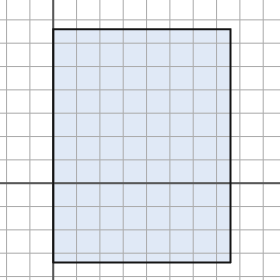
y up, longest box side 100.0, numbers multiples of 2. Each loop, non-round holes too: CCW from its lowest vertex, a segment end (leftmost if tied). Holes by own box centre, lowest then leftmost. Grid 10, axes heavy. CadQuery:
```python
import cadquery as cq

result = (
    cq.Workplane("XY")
    .moveTo(0.0, -34.0)
    .lineTo(76.0, -34.0)
    .lineTo(76.0, 66.0)
    .lineTo(0.0, 66.0)
    .close()
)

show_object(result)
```